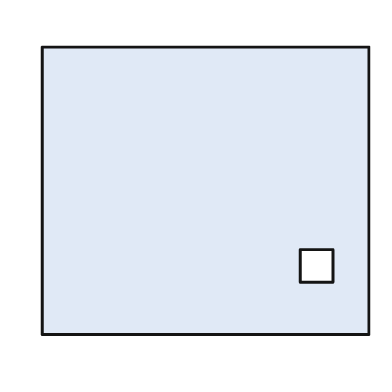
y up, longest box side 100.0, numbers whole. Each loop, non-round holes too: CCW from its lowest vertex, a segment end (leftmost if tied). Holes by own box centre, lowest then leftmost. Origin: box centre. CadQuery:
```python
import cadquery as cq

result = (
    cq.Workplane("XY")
    .moveTo(-50.0, -44.0)
    .lineTo(50.0, -44.0)
    .lineTo(50.0, 44.0)
    .lineTo(-50.0, 44.0)
    .close()
    .moveTo(29.0, -28.0)
    .lineTo(39.0, -28.0)
    .lineTo(39.0, -18.0)
    .lineTo(29.0, -18.0)
    .close()
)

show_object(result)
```